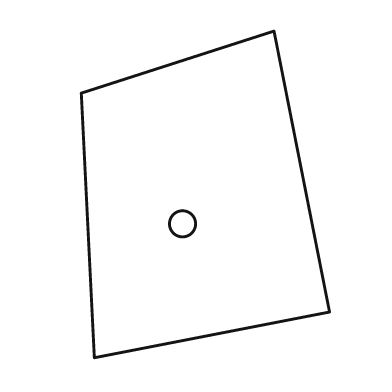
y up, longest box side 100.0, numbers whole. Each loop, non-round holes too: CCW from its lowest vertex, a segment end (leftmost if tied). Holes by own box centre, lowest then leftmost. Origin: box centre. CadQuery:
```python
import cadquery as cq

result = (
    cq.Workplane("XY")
    .moveTo(-34.0, -50.0)
    .lineTo(38.0, -36.0)
    .lineTo(21.0, 50.0)
    .lineTo(-38.0, 31.0)
    .close()
    .moveTo(-7.0, -9.0)
    .circle(4.0)
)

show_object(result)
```